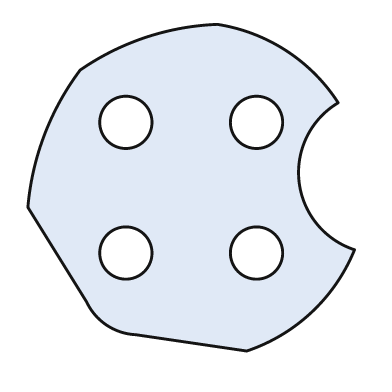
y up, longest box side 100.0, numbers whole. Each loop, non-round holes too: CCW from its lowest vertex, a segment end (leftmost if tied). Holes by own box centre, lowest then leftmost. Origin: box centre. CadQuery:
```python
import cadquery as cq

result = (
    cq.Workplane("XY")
    .moveTo(17.0, -50.0)
    .threePointArc((37.0, -38.0), (50.0, -19.0))
    .threePointArc((33.0, 2.0), (45.0, 26.0))
    .threePointArc((29.0, 42.0), (8.0, 50.0))
    .threePointArc((-14.0, 46.0), (-34.0, 36.0))
    .threePointArc((-45.0, 16.0), (-50.0, -6.0))
    .lineTo(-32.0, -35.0)
    .threePointArc((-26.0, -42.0), (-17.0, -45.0))
    .close()
    .moveTo(-20.0, -20.0)
    .circle(8.0)
    .moveTo(20.0, -20.0)
    .circle(8.0)
    .moveTo(-20.0, 20.0)
    .circle(8.0)
    .moveTo(20.0, 20.0)
    .circle(8.0)
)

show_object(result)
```